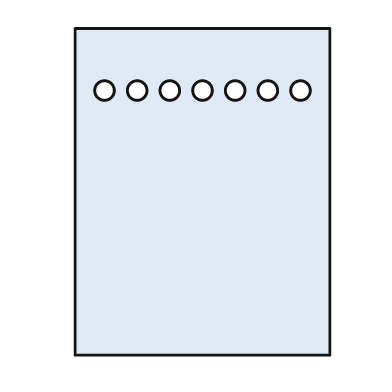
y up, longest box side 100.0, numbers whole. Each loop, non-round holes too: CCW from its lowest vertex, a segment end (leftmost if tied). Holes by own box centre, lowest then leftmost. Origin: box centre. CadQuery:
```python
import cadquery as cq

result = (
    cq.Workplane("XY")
    .moveTo(-39.0, -50.0)
    .lineTo(39.0, -50.0)
    .lineTo(39.0, 50.0)
    .lineTo(-39.0, 50.0)
    .close()
    .moveTo(-30.0, 31.0)
    .circle(3.0)
    .moveTo(-20.0, 31.0)
    .circle(3.0)
    .moveTo(-10.0, 31.0)
    .circle(3.0)
    .moveTo(0.0, 31.0)
    .circle(3.0)
    .moveTo(10.0, 31.0)
    .circle(3.0)
    .moveTo(20.0, 31.0)
    .circle(3.0)
    .moveTo(30.0, 31.0)
    .circle(3.0)
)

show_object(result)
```